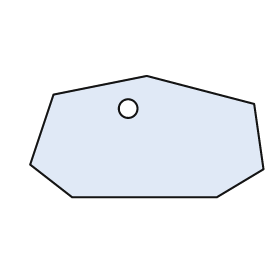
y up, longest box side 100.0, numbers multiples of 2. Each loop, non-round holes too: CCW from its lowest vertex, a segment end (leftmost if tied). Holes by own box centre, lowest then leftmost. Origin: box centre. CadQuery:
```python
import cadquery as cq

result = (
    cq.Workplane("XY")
    .moveTo(-32.0, -26.0)
    .lineTo(30.0, -26.0)
    .lineTo(50.0, -14.0)
    .lineTo(46.0, 14.0)
    .lineTo(0.0, 26.0)
    .lineTo(-40.0, 18.0)
    .lineTo(-50.0, -12.0)
    .close()
    .moveTo(-8.0, 12.0)
    .circle(4.0)
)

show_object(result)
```